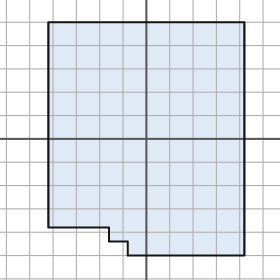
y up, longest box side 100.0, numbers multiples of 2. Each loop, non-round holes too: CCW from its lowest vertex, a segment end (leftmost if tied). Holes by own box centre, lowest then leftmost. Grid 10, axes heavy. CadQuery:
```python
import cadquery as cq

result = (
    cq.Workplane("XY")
    .moveTo(-8.0, -50.0)
    .lineTo(42.0, -50.0)
    .lineTo(42.0, 50.0)
    .lineTo(-42.0, 50.0)
    .lineTo(-42.0, -38.0)
    .lineTo(-16.0, -38.0)
    .lineTo(-16.0, -44.0)
    .lineTo(-8.0, -44.0)
    .close()
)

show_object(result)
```